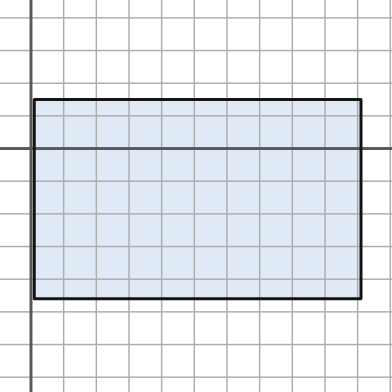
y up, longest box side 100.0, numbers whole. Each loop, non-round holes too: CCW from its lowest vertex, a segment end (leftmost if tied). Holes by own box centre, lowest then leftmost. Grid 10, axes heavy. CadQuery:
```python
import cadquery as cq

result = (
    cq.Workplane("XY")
    .moveTo(1.0, -46.0)
    .lineTo(101.0, -46.0)
    .lineTo(101.0, 15.0)
    .lineTo(1.0, 15.0)
    .close()
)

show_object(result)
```